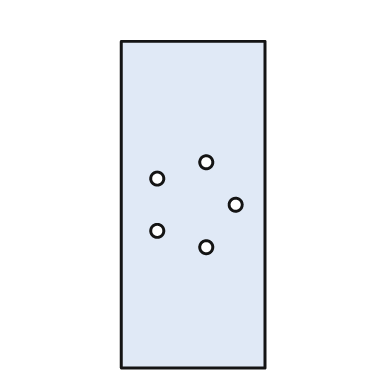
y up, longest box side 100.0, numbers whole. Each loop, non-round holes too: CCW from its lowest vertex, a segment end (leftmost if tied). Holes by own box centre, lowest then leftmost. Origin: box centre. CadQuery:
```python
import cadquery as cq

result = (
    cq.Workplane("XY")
    .moveTo(-22.0, -50.0)
    .lineTo(22.0, -50.0)
    .lineTo(22.0, 50.0)
    .lineTo(-22.0, 50.0)
    .close()
    .moveTo(4.0, -13.0)
    .circle(2.0)
    .moveTo(-11.0, -8.0)
    .circle(2.0)
    .moveTo(13.0, 0.0)
    .circle(2.0)
    .moveTo(-11.0, 8.0)
    .circle(2.0)
    .moveTo(4.0, 13.0)
    .circle(2.0)
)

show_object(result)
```